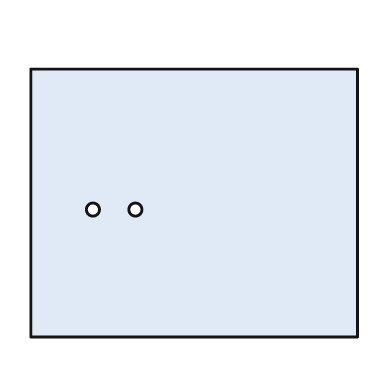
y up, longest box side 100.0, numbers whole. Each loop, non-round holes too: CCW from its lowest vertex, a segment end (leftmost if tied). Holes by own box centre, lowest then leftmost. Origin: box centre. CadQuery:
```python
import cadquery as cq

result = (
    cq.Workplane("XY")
    .moveTo(-50.0, -41.0)
    .lineTo(50.0, -41.0)
    .lineTo(50.0, 41.0)
    .lineTo(-50.0, 41.0)
    .close()
    .moveTo(-31.0, -2.0)
    .circle(2.0)
    .moveTo(-18.0, -2.0)
    .circle(2.0)
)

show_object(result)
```